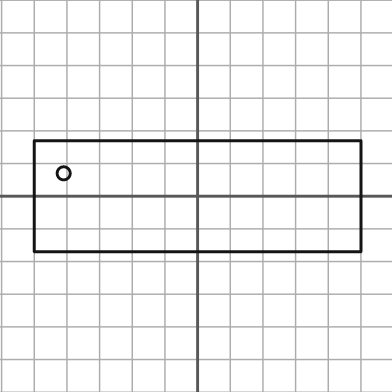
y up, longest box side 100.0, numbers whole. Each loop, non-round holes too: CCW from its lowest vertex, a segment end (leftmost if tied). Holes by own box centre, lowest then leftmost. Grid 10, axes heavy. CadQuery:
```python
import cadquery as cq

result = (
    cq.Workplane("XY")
    .moveTo(-50.0, -17.0)
    .lineTo(50.0, -17.0)
    .lineTo(50.0, 17.0)
    .lineTo(-50.0, 17.0)
    .close()
    .moveTo(-41.0, 7.0)
    .circle(2.0)
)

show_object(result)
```